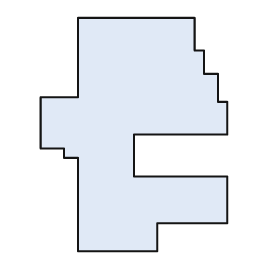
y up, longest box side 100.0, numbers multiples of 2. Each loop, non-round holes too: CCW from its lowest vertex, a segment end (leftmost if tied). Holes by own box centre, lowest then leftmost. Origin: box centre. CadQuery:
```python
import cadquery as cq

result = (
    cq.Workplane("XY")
    .moveTo(-24.0, -50.0)
    .lineTo(10.0, -50.0)
    .lineTo(10.0, -38.0)
    .lineTo(40.0, -38.0)
    .lineTo(40.0, -18.0)
    .lineTo(0.0, -18.0)
    .lineTo(0.0, 0.0)
    .lineTo(40.0, 0.0)
    .lineTo(40.0, 14.0)
    .lineTo(36.0, 14.0)
    .lineTo(36.0, 26.0)
    .lineTo(30.0, 26.0)
    .lineTo(30.0, 36.0)
    .lineTo(26.0, 36.0)
    .lineTo(26.0, 50.0)
    .lineTo(-24.0, 50.0)
    .lineTo(-24.0, 16.0)
    .lineTo(-40.0, 16.0)
    .lineTo(-40.0, -6.0)
    .lineTo(-30.0, -6.0)
    .lineTo(-30.0, -10.0)
    .lineTo(-24.0, -10.0)
    .close()
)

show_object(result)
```